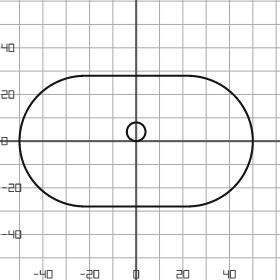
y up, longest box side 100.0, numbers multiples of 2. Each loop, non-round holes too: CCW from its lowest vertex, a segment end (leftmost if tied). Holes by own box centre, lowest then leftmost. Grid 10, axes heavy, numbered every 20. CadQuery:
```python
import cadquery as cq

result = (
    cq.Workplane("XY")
    .moveTo(-22.0, -28.0)
    .lineTo(22.0, -28.0)
    .threePointArc((50.0, 0.0), (22.0, 28.0))
    .lineTo(-22.0, 28.0)
    .threePointArc((-50.0, 0.0), (-22.0, -28.0))
    .close()
    .moveTo(0.0, 4.0)
    .circle(4.0)
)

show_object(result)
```